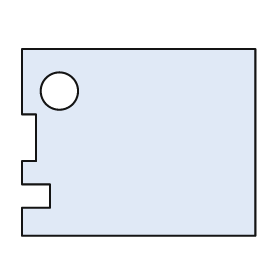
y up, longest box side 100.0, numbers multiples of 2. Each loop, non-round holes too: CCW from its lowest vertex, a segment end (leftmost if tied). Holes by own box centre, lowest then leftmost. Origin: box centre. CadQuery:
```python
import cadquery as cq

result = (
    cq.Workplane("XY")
    .moveTo(-50.0, -40.0)
    .lineTo(50.0, -40.0)
    .lineTo(50.0, 40.0)
    .lineTo(-50.0, 40.0)
    .lineTo(-50.0, 12.0)
    .lineTo(-44.0, 12.0)
    .lineTo(-44.0, -8.0)
    .lineTo(-50.0, -8.0)
    .lineTo(-50.0, -18.0)
    .lineTo(-38.0, -18.0)
    .lineTo(-38.0, -28.0)
    .lineTo(-50.0, -28.0)
    .close()
    .moveTo(-34.0, 22.0)
    .circle(8.0)
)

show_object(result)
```